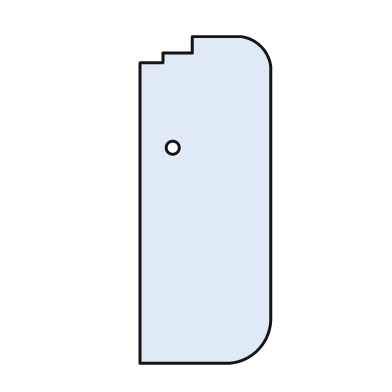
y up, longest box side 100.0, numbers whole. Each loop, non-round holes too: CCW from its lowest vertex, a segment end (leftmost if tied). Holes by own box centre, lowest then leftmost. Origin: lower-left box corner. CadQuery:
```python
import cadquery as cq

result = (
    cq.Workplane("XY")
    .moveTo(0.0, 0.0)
    .lineTo(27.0, 0.0)
    .threePointArc((36.0, 4.0), (40.0, 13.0))
    .lineTo(40.0, 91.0)
    .threePointArc((37.0, 97.0), (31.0, 100.0))
    .lineTo(16.0, 100.0)
    .lineTo(16.0, 95.0)
    .lineTo(7.0, 95.0)
    .lineTo(7.0, 92.0)
    .lineTo(0.0, 92.0)
    .close()
    .moveTo(10.0, 66.0)
    .circle(2.0)
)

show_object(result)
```